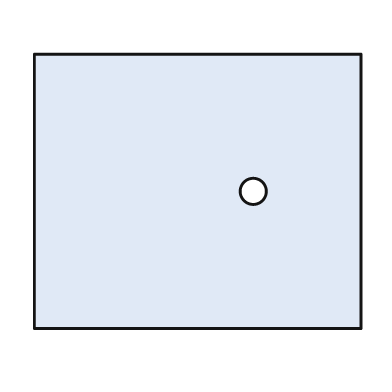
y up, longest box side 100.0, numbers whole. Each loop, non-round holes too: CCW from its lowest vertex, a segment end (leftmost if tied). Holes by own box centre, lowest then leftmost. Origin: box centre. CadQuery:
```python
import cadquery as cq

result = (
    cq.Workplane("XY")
    .moveTo(-50.0, -42.0)
    .lineTo(50.0, -42.0)
    .lineTo(50.0, 42.0)
    .lineTo(-50.0, 42.0)
    .close()
    .moveTo(17.0, 0.0)
    .circle(4.0)
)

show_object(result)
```